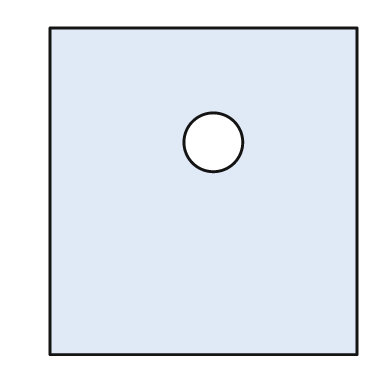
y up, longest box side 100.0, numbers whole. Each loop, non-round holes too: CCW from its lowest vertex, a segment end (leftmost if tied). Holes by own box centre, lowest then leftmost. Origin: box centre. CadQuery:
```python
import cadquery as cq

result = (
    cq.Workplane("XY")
    .moveTo(-47.0, -50.0)
    .lineTo(47.0, -50.0)
    .lineTo(47.0, 50.0)
    .lineTo(-47.0, 50.0)
    .close()
    .moveTo(3.0, 15.0)
    .circle(9.0)
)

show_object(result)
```